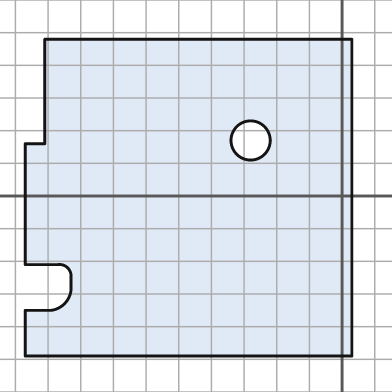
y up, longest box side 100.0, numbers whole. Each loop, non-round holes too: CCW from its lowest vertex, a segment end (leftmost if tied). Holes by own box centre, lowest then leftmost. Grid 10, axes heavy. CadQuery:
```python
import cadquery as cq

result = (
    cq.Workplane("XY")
    .moveTo(-97.0, -49.0)
    .lineTo(3.0, -49.0)
    .lineTo(3.0, 48.0)
    .lineTo(-91.0, 48.0)
    .lineTo(-91.0, 16.0)
    .lineTo(-97.0, 16.0)
    .lineTo(-97.0, -21.0)
    .lineTo(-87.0, -21.0)
    .threePointArc((-84.0, -22.0), (-83.0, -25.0))
    .lineTo(-83.0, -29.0)
    .threePointArc((-85.0, -33.0), (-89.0, -35.0))
    .lineTo(-97.0, -35.0)
    .close()
    .moveTo(-28.0, 17.0)
    .circle(6.0)
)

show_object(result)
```